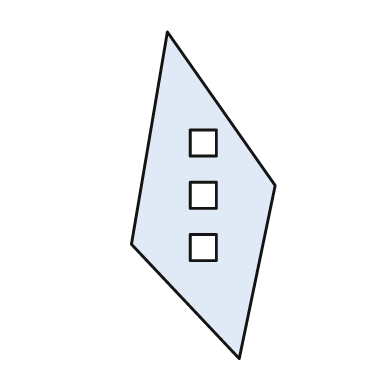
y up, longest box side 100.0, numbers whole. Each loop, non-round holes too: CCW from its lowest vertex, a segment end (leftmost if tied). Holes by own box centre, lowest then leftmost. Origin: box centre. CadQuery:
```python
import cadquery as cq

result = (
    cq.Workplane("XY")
    .moveTo(11.0, -50.0)
    .lineTo(22.0, 3.0)
    .lineTo(-11.0, 50.0)
    .lineTo(-22.0, -15.0)
    .close()
    .moveTo(-4.0, -20.0)
    .lineTo(4.0, -20.0)
    .lineTo(4.0, -12.0)
    .lineTo(-4.0, -12.0)
    .close()
    .moveTo(-4.0, -4.0)
    .lineTo(4.0, -4.0)
    .lineTo(4.0, 4.0)
    .lineTo(-4.0, 4.0)
    .close()
    .moveTo(-4.0, 12.0)
    .lineTo(4.0, 12.0)
    .lineTo(4.0, 20.0)
    .lineTo(-4.0, 20.0)
    .close()
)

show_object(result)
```